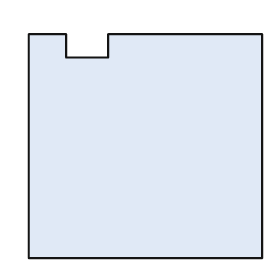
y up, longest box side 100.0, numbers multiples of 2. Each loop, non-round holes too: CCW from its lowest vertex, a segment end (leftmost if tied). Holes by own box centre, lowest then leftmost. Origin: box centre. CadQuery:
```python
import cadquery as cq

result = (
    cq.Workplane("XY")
    .moveTo(-50.0, -48.0)
    .lineTo(50.0, -48.0)
    .lineTo(50.0, 48.0)
    .lineTo(-16.0, 48.0)
    .lineTo(-16.0, 38.0)
    .lineTo(-34.0, 38.0)
    .lineTo(-34.0, 48.0)
    .lineTo(-50.0, 48.0)
    .close()
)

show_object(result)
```